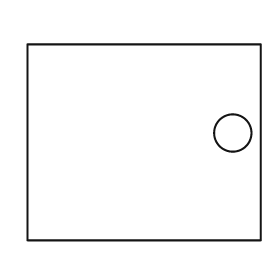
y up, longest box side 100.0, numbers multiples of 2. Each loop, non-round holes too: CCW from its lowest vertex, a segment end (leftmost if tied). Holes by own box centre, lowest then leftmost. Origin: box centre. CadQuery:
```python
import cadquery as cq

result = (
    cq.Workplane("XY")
    .moveTo(-50.0, -42.0)
    .lineTo(50.0, -42.0)
    .lineTo(50.0, 42.0)
    .lineTo(-50.0, 42.0)
    .close()
    .moveTo(38.0, 4.0)
    .circle(8.0)
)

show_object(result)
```